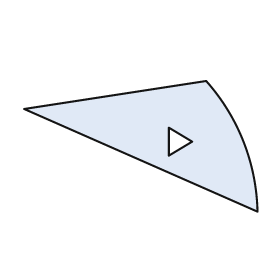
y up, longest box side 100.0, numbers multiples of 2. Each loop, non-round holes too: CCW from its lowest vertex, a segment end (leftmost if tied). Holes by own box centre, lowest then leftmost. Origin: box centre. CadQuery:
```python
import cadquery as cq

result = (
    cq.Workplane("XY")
    .moveTo(50.0, -28.0)
    .threePointArc((44.0, 2.0), (28.0, 28.0))
    .lineTo(-50.0, 16.0)
    .close()
    .moveTo(12.0, -4.0)
    .lineTo(22.0, 2.0)
    .lineTo(12.0, 8.0)
    .close()
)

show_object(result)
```